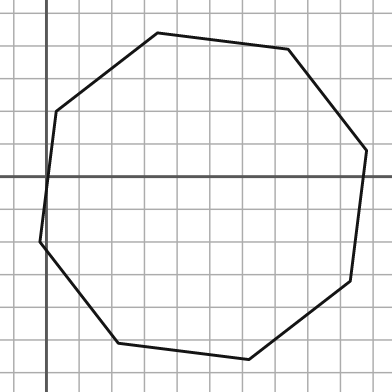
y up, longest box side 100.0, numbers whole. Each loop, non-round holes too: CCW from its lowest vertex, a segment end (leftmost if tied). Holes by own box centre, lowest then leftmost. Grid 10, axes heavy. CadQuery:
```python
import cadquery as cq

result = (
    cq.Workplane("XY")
    .moveTo(62.0, -56.0)
    .lineTo(93.0, -32.0)
    .lineTo(98.0, 8.0)
    .lineTo(74.0, 39.0)
    .lineTo(34.0, 44.0)
    .lineTo(3.0, 20.0)
    .lineTo(-2.0, -20.0)
    .lineTo(22.0, -51.0)
    .close()
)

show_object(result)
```